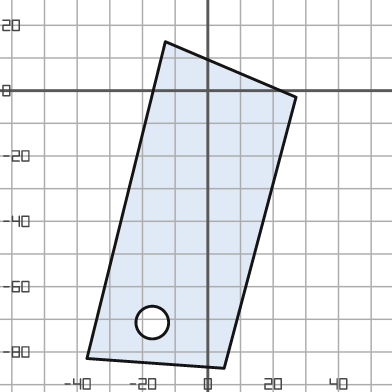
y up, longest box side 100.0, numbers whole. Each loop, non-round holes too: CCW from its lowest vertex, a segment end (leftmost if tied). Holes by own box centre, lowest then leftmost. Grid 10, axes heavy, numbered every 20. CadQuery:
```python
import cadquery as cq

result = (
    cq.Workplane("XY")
    .moveTo(5.0, -85.0)
    .lineTo(27.0, -2.0)
    .lineTo(-13.0, 15.0)
    .lineTo(-37.0, -82.0)
    .close()
    .moveTo(-17.0, -71.0)
    .circle(5.0)
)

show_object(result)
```